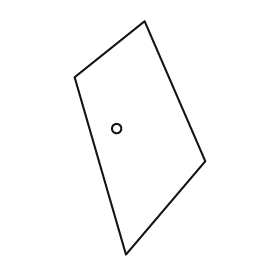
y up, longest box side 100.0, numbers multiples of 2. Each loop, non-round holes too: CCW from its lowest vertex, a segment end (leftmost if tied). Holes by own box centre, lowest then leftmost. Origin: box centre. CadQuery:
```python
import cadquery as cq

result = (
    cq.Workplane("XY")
    .moveTo(-6.0, -50.0)
    .lineTo(28.0, -10.0)
    .lineTo(2.0, 50.0)
    .lineTo(-28.0, 26.0)
    .close()
    .moveTo(-10.0, 4.0)
    .circle(2.0)
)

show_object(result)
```